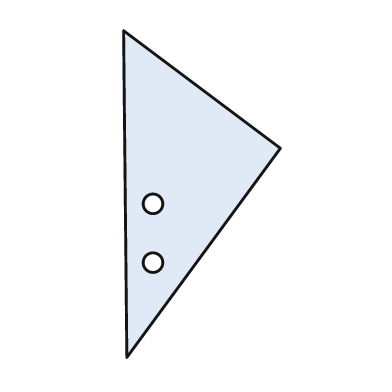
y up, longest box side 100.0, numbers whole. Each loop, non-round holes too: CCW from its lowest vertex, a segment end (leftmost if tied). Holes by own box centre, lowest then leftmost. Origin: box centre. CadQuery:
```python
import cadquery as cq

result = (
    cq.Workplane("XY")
    .moveTo(-23.0, -50.0)
    .lineTo(24.0, 14.0)
    .lineTo(-24.0, 50.0)
    .close()
    .moveTo(-15.0, -21.0)
    .circle(3.0)
    .moveTo(-15.0, -3.0)
    .circle(3.0)
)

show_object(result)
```